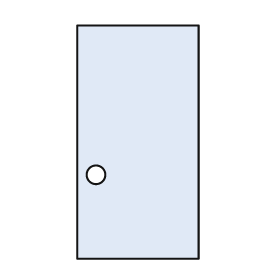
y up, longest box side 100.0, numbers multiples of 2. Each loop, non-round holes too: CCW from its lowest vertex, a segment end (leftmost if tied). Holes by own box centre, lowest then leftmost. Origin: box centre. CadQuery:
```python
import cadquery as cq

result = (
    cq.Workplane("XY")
    .moveTo(-26.0, -50.0)
    .lineTo(26.0, -50.0)
    .lineTo(26.0, 50.0)
    .lineTo(-26.0, 50.0)
    .close()
    .moveTo(-18.0, -14.0)
    .circle(4.0)
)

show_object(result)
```